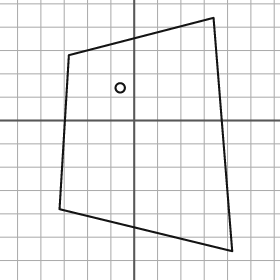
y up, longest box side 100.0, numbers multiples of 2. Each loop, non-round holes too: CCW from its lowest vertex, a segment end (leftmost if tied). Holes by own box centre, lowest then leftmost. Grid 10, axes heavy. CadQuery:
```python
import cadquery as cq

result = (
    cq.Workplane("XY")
    .moveTo(42.0, -56.0)
    .lineTo(34.0, 44.0)
    .lineTo(-28.0, 28.0)
    .lineTo(-32.0, -38.0)
    .close()
    .moveTo(-6.0, 14.0)
    .circle(2.0)
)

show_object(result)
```